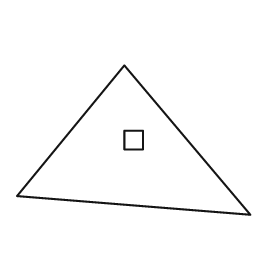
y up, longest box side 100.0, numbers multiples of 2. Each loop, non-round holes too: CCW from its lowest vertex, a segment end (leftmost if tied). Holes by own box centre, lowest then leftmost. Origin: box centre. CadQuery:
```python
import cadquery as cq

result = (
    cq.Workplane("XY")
    .moveTo(50.0, -32.0)
    .lineTo(-4.0, 32.0)
    .lineTo(-50.0, -24.0)
    .close()
    .moveTo(-4.0, -4.0)
    .lineTo(4.0, -4.0)
    .lineTo(4.0, 4.0)
    .lineTo(-4.0, 4.0)
    .close()
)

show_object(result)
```